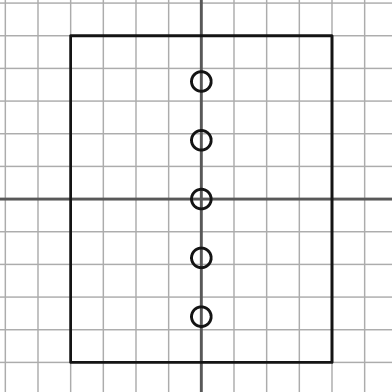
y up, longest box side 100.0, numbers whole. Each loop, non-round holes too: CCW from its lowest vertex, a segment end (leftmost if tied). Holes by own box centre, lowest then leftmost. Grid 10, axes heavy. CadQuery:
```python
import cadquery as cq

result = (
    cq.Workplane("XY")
    .moveTo(-40.0, -50.0)
    .lineTo(40.0, -50.0)
    .lineTo(40.0, 50.0)
    .lineTo(-40.0, 50.0)
    .close()
    .moveTo(0.0, -36.0)
    .circle(3.0)
    .moveTo(0.0, -18.0)
    .circle(3.0)
    .moveTo(0.0, 0.0)
    .circle(3.0)
    .moveTo(0.0, 18.0)
    .circle(3.0)
    .moveTo(0.0, 36.0)
    .circle(3.0)
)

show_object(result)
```